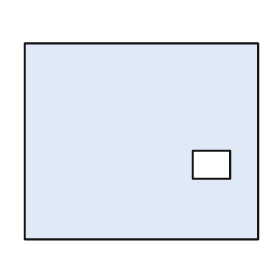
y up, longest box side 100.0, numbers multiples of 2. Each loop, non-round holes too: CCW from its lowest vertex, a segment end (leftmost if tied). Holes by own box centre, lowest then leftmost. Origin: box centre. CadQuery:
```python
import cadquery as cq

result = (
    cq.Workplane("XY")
    .moveTo(-50.0, -42.0)
    .lineTo(50.0, -42.0)
    .lineTo(50.0, 42.0)
    .lineTo(-50.0, 42.0)
    .close()
    .moveTo(22.0, -16.0)
    .lineTo(38.0, -16.0)
    .lineTo(38.0, -4.0)
    .lineTo(22.0, -4.0)
    .close()
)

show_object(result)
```